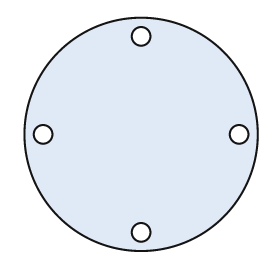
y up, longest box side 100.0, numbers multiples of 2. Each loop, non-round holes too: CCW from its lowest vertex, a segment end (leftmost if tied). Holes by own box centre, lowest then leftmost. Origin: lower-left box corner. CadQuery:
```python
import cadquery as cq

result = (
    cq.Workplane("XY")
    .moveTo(50.0, 50.0)
    .circle(50.0)
    .moveTo(50.0, 8.0)
    .circle(4.0)
    .moveTo(8.0, 50.0)
    .circle(4.0)
    .moveTo(92.0, 50.0)
    .circle(4.0)
    .moveTo(50.0, 92.0)
    .circle(4.0)
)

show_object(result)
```